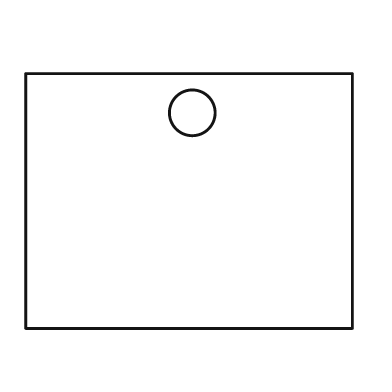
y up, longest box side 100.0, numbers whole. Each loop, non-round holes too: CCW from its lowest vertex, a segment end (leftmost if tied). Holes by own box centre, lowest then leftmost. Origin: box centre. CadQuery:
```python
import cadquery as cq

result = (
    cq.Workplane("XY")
    .moveTo(-50.0, -39.0)
    .lineTo(50.0, -39.0)
    .lineTo(50.0, 39.0)
    .lineTo(-50.0, 39.0)
    .close()
    .moveTo(1.0, 27.0)
    .circle(7.0)
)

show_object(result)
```